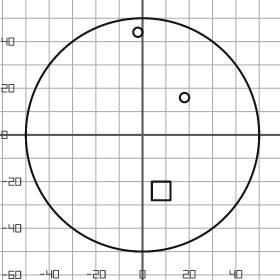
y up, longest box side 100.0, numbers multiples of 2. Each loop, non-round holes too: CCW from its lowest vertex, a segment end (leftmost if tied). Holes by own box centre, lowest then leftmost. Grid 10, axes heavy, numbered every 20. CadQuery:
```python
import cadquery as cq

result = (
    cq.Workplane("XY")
    .moveTo(0.0, 0.0)
    .circle(50.0)
    .moveTo(4.0, -28.0)
    .lineTo(12.0, -28.0)
    .lineTo(12.0, -20.0)
    .lineTo(4.0, -20.0)
    .close()
    .moveTo(18.0, 16.0)
    .circle(2.0)
    .moveTo(-2.0, 44.0)
    .circle(2.0)
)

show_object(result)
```